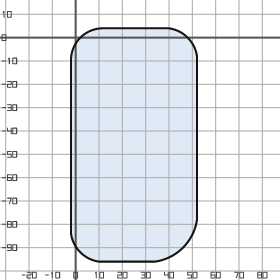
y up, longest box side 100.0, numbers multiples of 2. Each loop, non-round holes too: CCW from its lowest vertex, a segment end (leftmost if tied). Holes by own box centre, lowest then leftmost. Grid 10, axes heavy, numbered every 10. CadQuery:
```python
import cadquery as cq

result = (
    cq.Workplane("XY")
    .moveTo(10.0, -96.0)
    .lineTo(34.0, -96.0)
    .threePointArc((46.0, -90.0), (52.0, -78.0))
    .lineTo(52.0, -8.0)
    .threePointArc((48.0, 0.0), (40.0, 4.0))
    .lineTo(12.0, 4.0)
    .threePointArc((2.0, 0.0), (-2.0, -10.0))
    .lineTo(-2.0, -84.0)
    .threePointArc((2.0, -92.0), (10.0, -96.0))
    .close()
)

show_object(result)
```